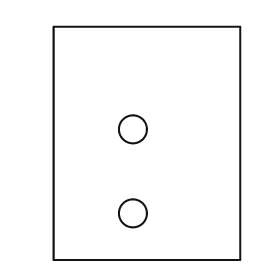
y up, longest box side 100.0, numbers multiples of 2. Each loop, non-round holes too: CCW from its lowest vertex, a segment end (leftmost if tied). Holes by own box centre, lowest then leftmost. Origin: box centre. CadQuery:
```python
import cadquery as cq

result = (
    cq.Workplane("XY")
    .moveTo(-40.0, -50.0)
    .lineTo(40.0, -50.0)
    .lineTo(40.0, 50.0)
    .lineTo(-40.0, 50.0)
    .close()
    .moveTo(-6.0, -30.0)
    .circle(6.0)
    .moveTo(-6.0, 6.0)
    .circle(6.0)
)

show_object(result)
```